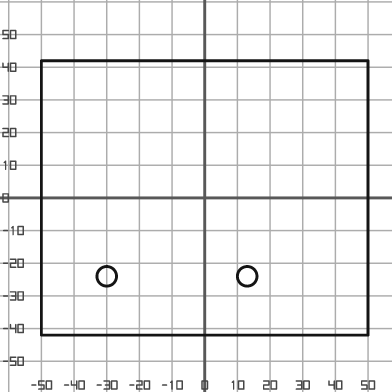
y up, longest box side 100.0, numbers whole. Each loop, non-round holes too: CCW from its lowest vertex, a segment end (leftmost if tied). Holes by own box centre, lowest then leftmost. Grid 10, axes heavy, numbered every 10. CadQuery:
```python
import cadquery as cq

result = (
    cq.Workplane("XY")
    .moveTo(-50.0, -42.0)
    .lineTo(50.0, -42.0)
    .lineTo(50.0, 42.0)
    .lineTo(-50.0, 42.0)
    .close()
    .moveTo(-30.0, -24.0)
    .circle(3.0)
    .moveTo(13.0, -24.0)
    .circle(3.0)
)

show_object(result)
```